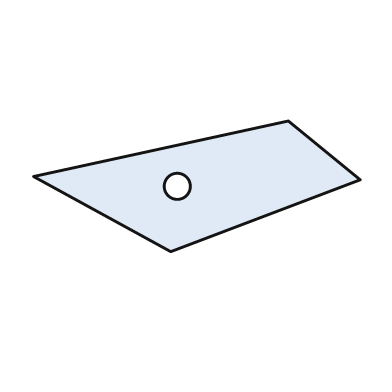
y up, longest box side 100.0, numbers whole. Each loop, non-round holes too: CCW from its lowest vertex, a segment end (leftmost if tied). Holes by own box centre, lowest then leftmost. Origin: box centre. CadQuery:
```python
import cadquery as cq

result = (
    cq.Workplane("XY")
    .moveTo(-8.0, -20.0)
    .lineTo(50.0, 2.0)
    .lineTo(28.0, 20.0)
    .lineTo(-50.0, 3.0)
    .close()
    .moveTo(-6.0, 0.0)
    .circle(4.0)
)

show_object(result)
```